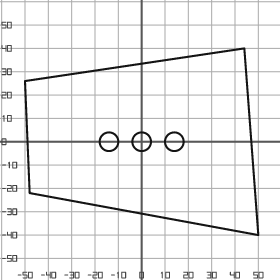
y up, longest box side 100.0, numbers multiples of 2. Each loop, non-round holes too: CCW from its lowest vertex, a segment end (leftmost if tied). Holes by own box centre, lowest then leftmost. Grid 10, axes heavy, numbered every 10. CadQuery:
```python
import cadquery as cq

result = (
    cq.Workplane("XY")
    .moveTo(50.0, -40.0)
    .lineTo(44.0, 40.0)
    .lineTo(-50.0, 26.0)
    .lineTo(-48.0, -22.0)
    .close()
    .moveTo(-14.0, 0.0)
    .circle(4.0)
    .moveTo(0.0, 0.0)
    .circle(4.0)
    .moveTo(14.0, 0.0)
    .circle(4.0)
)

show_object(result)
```